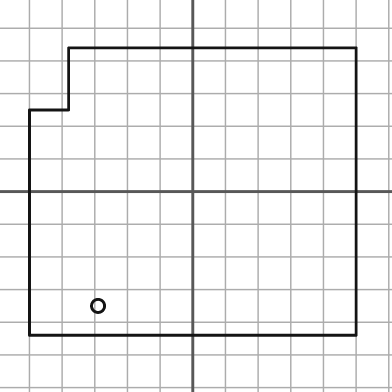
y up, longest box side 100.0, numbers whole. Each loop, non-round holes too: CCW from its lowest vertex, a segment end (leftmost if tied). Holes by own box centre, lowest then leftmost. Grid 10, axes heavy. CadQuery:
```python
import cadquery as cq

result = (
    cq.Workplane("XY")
    .moveTo(-50.0, -44.0)
    .lineTo(50.0, -44.0)
    .lineTo(50.0, 44.0)
    .lineTo(-38.0, 44.0)
    .lineTo(-38.0, 25.0)
    .lineTo(-50.0, 25.0)
    .close()
    .moveTo(-29.0, -35.0)
    .circle(2.0)
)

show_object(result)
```